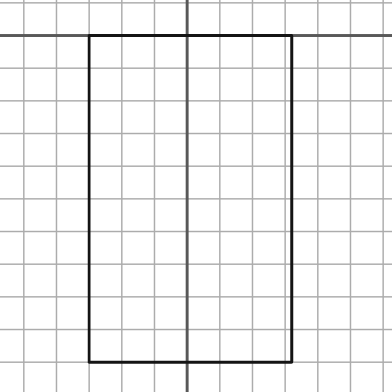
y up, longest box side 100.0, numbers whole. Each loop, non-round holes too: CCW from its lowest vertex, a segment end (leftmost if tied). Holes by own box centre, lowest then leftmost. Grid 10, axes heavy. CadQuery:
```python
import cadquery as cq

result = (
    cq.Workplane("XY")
    .moveTo(-30.0, -100.0)
    .lineTo(32.0, -100.0)
    .lineTo(32.0, 0.0)
    .lineTo(-30.0, 0.0)
    .close()
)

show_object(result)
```